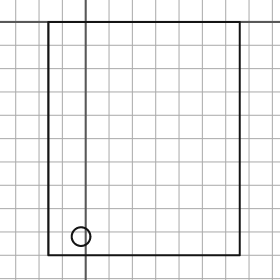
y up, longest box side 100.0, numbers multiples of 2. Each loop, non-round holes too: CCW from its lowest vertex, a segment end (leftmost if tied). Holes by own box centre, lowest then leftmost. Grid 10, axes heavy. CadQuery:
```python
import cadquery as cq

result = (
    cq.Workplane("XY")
    .moveTo(-16.0, -100.0)
    .lineTo(66.0, -100.0)
    .lineTo(66.0, 0.0)
    .lineTo(-16.0, 0.0)
    .close()
    .moveTo(-2.0, -92.0)
    .circle(4.0)
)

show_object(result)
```